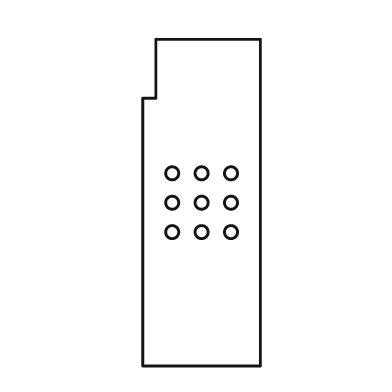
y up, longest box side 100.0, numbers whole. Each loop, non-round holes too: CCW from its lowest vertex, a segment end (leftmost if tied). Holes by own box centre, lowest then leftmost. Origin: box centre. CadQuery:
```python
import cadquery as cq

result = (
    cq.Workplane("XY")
    .moveTo(-18.0, -50.0)
    .lineTo(18.0, -50.0)
    .lineTo(18.0, 50.0)
    .lineTo(-14.0, 50.0)
    .lineTo(-14.0, 32.0)
    .lineTo(-18.0, 32.0)
    .close()
    .moveTo(-9.0, -9.0)
    .circle(2.0)
    .moveTo(0.0, -9.0)
    .circle(2.0)
    .moveTo(9.0, -9.0)
    .circle(2.0)
    .moveTo(-9.0, 0.0)
    .circle(2.0)
    .moveTo(0.0, 0.0)
    .circle(2.0)
    .moveTo(9.0, 0.0)
    .circle(2.0)
    .moveTo(-9.0, 9.0)
    .circle(2.0)
    .moveTo(0.0, 9.0)
    .circle(2.0)
    .moveTo(9.0, 9.0)
    .circle(2.0)
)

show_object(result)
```